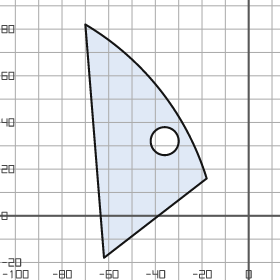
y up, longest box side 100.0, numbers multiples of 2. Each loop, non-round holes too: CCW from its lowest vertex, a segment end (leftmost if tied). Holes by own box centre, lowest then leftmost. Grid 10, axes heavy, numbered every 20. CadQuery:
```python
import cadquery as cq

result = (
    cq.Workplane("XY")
    .moveTo(-62.0, -18.0)
    .lineTo(-18.0, 16.0)
    .threePointArc((-38.0, 54.0), (-70.0, 82.0))
    .close()
    .moveTo(-36.0, 32.0)
    .circle(6.0)
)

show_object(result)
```